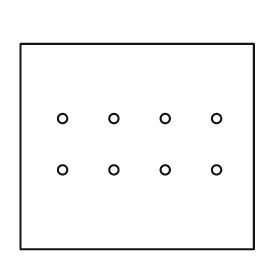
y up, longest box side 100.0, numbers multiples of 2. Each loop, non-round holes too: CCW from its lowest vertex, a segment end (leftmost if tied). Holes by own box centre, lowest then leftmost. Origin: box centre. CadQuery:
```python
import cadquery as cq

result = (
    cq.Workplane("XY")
    .moveTo(-50.0, -44.0)
    .lineTo(50.0, -44.0)
    .lineTo(50.0, 44.0)
    .lineTo(-50.0, 44.0)
    .close()
    .moveTo(-32.0, -10.0)
    .circle(2.0)
    .moveTo(-10.0, -10.0)
    .circle(2.0)
    .moveTo(12.0, -10.0)
    .circle(2.0)
    .moveTo(34.0, -10.0)
    .circle(2.0)
    .moveTo(-32.0, 12.0)
    .circle(2.0)
    .moveTo(-10.0, 12.0)
    .circle(2.0)
    .moveTo(12.0, 12.0)
    .circle(2.0)
    .moveTo(34.0, 12.0)
    .circle(2.0)
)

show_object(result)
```